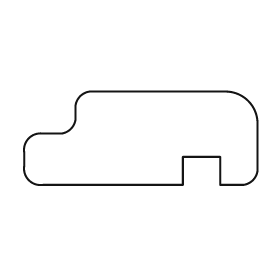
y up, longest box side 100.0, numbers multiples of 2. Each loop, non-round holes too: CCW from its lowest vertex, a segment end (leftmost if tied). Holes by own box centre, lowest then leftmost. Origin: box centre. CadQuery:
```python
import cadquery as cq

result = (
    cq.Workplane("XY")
    .moveTo(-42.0, -20.0)
    .lineTo(18.0, -20.0)
    .lineTo(18.0, -8.0)
    .lineTo(34.0, -8.0)
    .lineTo(34.0, -20.0)
    .lineTo(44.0, -20.0)
    .threePointArc((48.0, -18.0), (50.0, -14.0))
    .lineTo(50.0, 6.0)
    .threePointArc((46.0, 16.0), (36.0, 20.0))
    .lineTo(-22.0, 20.0)
    .threePointArc((-26.0, 18.0), (-28.0, 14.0))
    .lineTo(-28.0, 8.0)
    .threePointArc((-30.0, 4.0), (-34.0, 2.0))
    .lineTo(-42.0, 2.0)
    .threePointArc((-48.0, 0.0), (-50.0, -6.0))
    .lineTo(-50.0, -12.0)
    .threePointArc((-48.0, -18.0), (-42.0, -20.0))
    .close()
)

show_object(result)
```